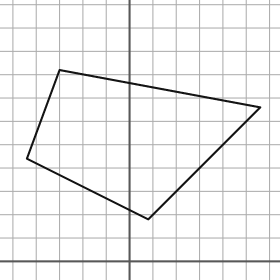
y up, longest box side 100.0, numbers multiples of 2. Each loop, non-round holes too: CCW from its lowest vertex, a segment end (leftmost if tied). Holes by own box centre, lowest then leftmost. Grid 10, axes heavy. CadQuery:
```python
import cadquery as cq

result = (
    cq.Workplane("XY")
    .moveTo(8.0, 18.0)
    .lineTo(56.0, 66.0)
    .lineTo(-30.0, 82.0)
    .lineTo(-44.0, 44.0)
    .close()
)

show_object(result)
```